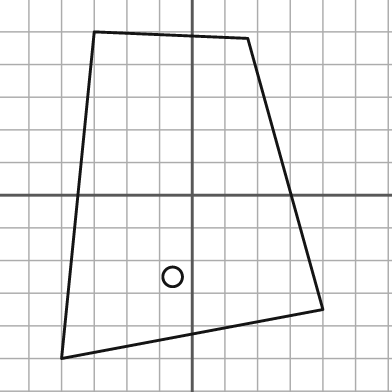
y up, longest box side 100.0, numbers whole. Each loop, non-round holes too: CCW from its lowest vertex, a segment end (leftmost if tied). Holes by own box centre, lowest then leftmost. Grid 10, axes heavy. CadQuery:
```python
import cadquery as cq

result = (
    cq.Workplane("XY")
    .moveTo(-40.0, -50.0)
    .lineTo(40.0, -35.0)
    .lineTo(17.0, 48.0)
    .lineTo(-30.0, 50.0)
    .close()
    .moveTo(-6.0, -25.0)
    .circle(3.0)
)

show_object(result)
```